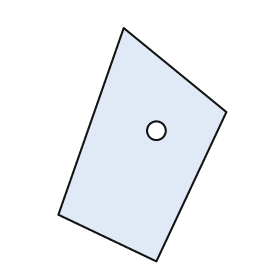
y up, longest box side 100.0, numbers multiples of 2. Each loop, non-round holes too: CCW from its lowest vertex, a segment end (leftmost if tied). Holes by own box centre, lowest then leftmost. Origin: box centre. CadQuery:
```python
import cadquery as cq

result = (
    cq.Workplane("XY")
    .moveTo(6.0, -50.0)
    .lineTo(36.0, 14.0)
    .lineTo(-8.0, 50.0)
    .lineTo(-36.0, -30.0)
    .close()
    .moveTo(6.0, 6.0)
    .circle(4.0)
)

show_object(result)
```